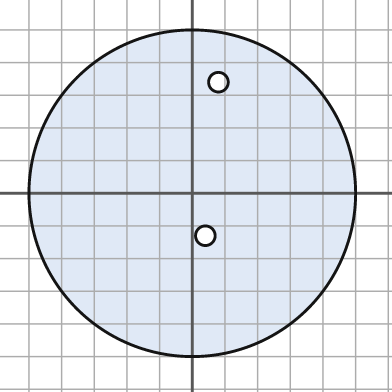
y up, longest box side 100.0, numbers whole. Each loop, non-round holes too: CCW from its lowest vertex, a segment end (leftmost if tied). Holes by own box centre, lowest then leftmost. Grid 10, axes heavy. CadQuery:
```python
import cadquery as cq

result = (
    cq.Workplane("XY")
    .moveTo(0.0, 0.0)
    .circle(50.0)
    .moveTo(4.0, -13.0)
    .circle(3.0)
    .moveTo(8.0, 34.0)
    .circle(3.0)
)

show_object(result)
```